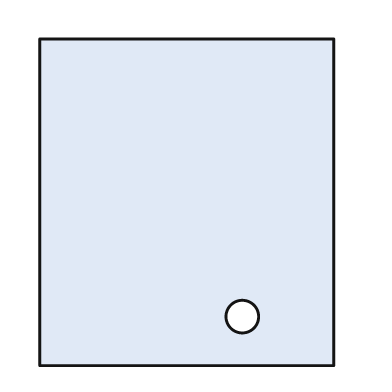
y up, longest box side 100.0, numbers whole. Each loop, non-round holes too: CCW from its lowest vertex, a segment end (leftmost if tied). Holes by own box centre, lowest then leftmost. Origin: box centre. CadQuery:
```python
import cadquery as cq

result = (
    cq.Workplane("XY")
    .moveTo(-45.0, -50.0)
    .lineTo(45.0, -50.0)
    .lineTo(45.0, 50.0)
    .lineTo(-45.0, 50.0)
    .close()
    .moveTo(17.0, -35.0)
    .circle(5.0)
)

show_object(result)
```